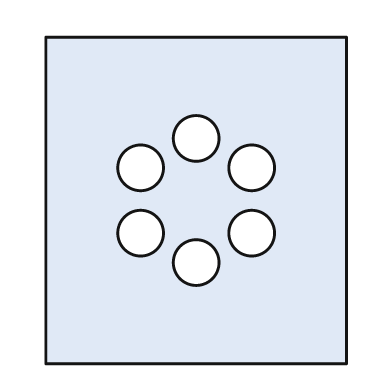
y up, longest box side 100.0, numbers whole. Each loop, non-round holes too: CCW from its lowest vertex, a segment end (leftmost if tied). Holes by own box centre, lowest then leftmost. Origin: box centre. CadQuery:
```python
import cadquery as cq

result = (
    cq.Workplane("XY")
    .moveTo(-46.0, -50.0)
    .lineTo(46.0, -50.0)
    .lineTo(46.0, 50.0)
    .lineTo(-46.0, 50.0)
    .close()
    .moveTo(0.0, -19.0)
    .circle(7.0)
    .moveTo(-17.0, -10.0)
    .circle(7.0)
    .moveTo(17.0, -10.0)
    .circle(7.0)
    .moveTo(-17.0, 10.0)
    .circle(7.0)
    .moveTo(17.0, 10.0)
    .circle(7.0)
    .moveTo(0.0, 19.0)
    .circle(7.0)
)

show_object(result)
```